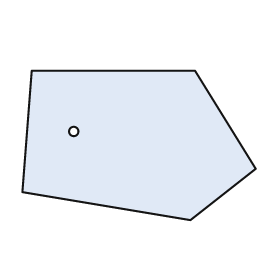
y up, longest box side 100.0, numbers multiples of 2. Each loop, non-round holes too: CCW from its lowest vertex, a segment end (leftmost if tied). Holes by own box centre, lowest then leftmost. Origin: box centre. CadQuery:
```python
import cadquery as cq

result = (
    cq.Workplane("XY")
    .moveTo(22.0, -32.0)
    .lineTo(50.0, -10.0)
    .lineTo(24.0, 32.0)
    .lineTo(-46.0, 32.0)
    .lineTo(-50.0, -20.0)
    .close()
    .moveTo(-28.0, 6.0)
    .circle(2.0)
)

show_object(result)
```